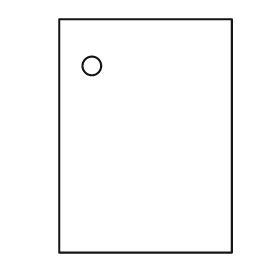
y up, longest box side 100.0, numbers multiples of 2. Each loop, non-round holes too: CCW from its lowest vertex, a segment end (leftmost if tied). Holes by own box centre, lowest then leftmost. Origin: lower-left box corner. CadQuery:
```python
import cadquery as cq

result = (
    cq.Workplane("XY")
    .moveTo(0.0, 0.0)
    .lineTo(74.0, 0.0)
    .lineTo(74.0, 100.0)
    .lineTo(0.0, 100.0)
    .close()
    .moveTo(14.0, 80.0)
    .circle(4.0)
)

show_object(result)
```